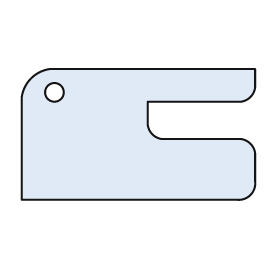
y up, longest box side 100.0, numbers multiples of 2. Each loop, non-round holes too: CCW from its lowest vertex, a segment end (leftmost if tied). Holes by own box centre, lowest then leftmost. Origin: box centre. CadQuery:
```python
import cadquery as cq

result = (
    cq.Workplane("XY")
    .moveTo(-50.0, -28.0)
    .lineTo(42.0, -28.0)
    .threePointArc((48.0, -26.0), (50.0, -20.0))
    .lineTo(50.0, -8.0)
    .threePointArc((48.0, -4.0), (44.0, -2.0))
    .lineTo(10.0, -2.0)
    .threePointArc((6.0, 0.0), (4.0, 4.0))
    .lineTo(4.0, 14.0)
    .lineTo(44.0, 14.0)
    .threePointArc((48.0, 16.0), (50.0, 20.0))
    .lineTo(50.0, 28.0)
    .lineTo(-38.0, 28.0)
    .threePointArc((-46.0, 24.0), (-50.0, 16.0))
    .close()
    .moveTo(-36.0, 18.0)
    .circle(4.0)
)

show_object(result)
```